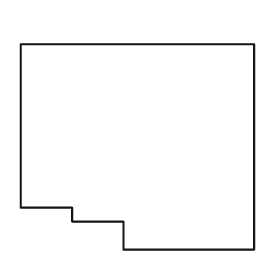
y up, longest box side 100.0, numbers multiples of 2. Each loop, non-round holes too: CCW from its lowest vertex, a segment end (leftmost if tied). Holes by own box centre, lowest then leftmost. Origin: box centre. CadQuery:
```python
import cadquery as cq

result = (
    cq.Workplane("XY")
    .moveTo(-6.0, -44.0)
    .lineTo(50.0, -44.0)
    .lineTo(50.0, 44.0)
    .lineTo(-50.0, 44.0)
    .lineTo(-50.0, -26.0)
    .lineTo(-28.0, -26.0)
    .lineTo(-28.0, -32.0)
    .lineTo(-6.0, -32.0)
    .close()
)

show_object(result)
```